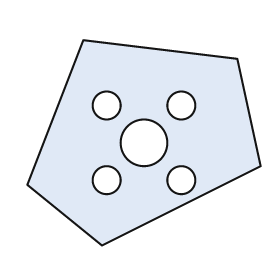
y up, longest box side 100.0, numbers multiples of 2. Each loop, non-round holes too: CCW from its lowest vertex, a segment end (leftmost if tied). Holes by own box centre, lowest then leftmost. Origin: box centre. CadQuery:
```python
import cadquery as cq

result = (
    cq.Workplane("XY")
    .moveTo(-18.0, -44.0)
    .lineTo(50.0, -10.0)
    .lineTo(40.0, 36.0)
    .lineTo(-26.0, 44.0)
    .lineTo(-50.0, -18.0)
    .close()
    .moveTo(-16.0, -16.0)
    .circle(6.0)
    .moveTo(16.0, -16.0)
    .circle(6.0)
    .moveTo(0.0, 0.0)
    .circle(10.0)
    .moveTo(-16.0, 16.0)
    .circle(6.0)
    .moveTo(16.0, 16.0)
    .circle(6.0)
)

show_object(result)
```